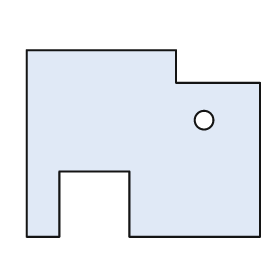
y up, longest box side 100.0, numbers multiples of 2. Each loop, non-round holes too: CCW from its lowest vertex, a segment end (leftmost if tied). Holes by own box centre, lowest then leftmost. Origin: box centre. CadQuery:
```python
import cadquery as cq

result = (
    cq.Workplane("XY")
    .moveTo(-50.0, -40.0)
    .lineTo(-36.0, -40.0)
    .lineTo(-36.0, -12.0)
    .lineTo(-6.0, -12.0)
    .lineTo(-6.0, -40.0)
    .lineTo(50.0, -40.0)
    .lineTo(50.0, 26.0)
    .lineTo(14.0, 26.0)
    .lineTo(14.0, 40.0)
    .lineTo(-50.0, 40.0)
    .close()
    .moveTo(26.0, 10.0)
    .circle(4.0)
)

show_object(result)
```